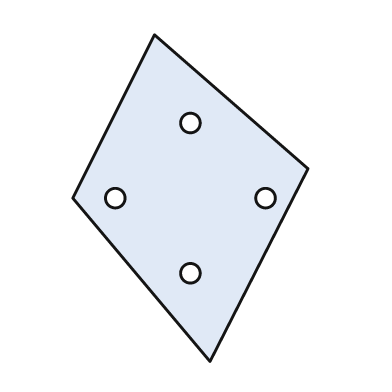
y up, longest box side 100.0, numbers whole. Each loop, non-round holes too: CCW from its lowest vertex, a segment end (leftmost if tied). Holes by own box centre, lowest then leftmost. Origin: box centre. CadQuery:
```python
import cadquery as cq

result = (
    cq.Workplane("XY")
    .moveTo(6.0, -50.0)
    .lineTo(36.0, 9.0)
    .lineTo(-11.0, 50.0)
    .lineTo(-36.0, 0.0)
    .close()
    .moveTo(0.0, -23.0)
    .circle(3.0)
    .moveTo(-23.0, 0.0)
    .circle(3.0)
    .moveTo(23.0, 0.0)
    .circle(3.0)
    .moveTo(0.0, 23.0)
    .circle(3.0)
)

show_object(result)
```